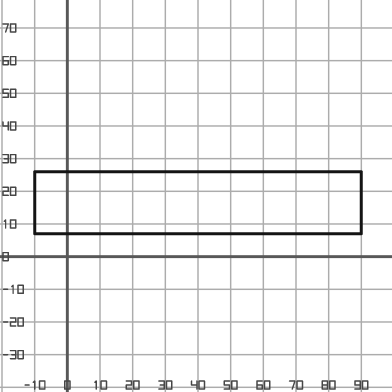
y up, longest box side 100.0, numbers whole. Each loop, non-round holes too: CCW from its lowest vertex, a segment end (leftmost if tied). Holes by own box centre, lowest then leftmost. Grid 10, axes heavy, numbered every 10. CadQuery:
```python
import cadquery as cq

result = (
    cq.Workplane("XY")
    .moveTo(-10.0, 7.0)
    .lineTo(90.0, 7.0)
    .lineTo(90.0, 26.0)
    .lineTo(-10.0, 26.0)
    .close()
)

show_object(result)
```